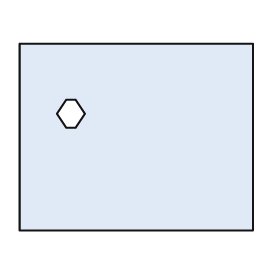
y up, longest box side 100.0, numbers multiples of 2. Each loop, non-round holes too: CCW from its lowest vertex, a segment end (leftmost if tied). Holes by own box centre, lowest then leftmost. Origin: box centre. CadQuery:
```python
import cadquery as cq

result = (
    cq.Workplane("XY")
    .moveTo(-50.0, -40.0)
    .lineTo(50.0, -40.0)
    .lineTo(50.0, 40.0)
    .lineTo(-50.0, 40.0)
    .close()
    .moveTo(-30.0, 4.0)
    .lineTo(-26.0, 4.0)
    .lineTo(-22.0, 10.0)
    .lineTo(-26.0, 16.0)
    .lineTo(-30.0, 16.0)
    .lineTo(-34.0, 10.0)
    .close()
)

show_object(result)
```